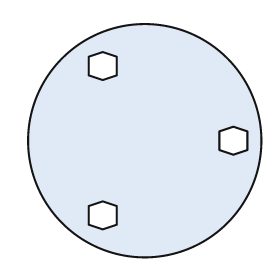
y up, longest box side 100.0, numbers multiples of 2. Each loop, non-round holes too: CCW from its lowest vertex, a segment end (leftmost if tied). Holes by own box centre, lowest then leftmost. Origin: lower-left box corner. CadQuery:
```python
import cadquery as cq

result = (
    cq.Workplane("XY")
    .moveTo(50.0, 50.0)
    .circle(50.0)
    .moveTo(32.0, 12.0)
    .lineTo(38.0, 14.0)
    .lineTo(38.0, 22.0)
    .lineTo(32.0, 24.0)
    .lineTo(26.0, 22.0)
    .lineTo(26.0, 14.0)
    .close()
    .moveTo(88.0, 44.0)
    .lineTo(94.0, 46.0)
    .lineTo(94.0, 54.0)
    .lineTo(88.0, 56.0)
    .lineTo(82.0, 54.0)
    .lineTo(82.0, 46.0)
    .close()
    .moveTo(32.0, 76.0)
    .lineTo(38.0, 78.0)
    .lineTo(38.0, 86.0)
    .lineTo(32.0, 88.0)
    .lineTo(26.0, 86.0)
    .lineTo(26.0, 78.0)
    .close()
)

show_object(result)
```